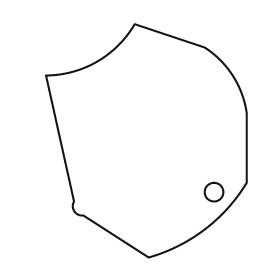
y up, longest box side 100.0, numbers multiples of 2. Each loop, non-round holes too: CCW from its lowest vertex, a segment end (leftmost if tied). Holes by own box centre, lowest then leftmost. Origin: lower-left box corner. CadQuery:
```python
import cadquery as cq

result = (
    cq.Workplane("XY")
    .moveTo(44.0, 0.0)
    .threePointArc((68.0, 12.0), (86.0, 32.0))
    .lineTo(86.0, 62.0)
    .threePointArc((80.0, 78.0), (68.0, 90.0))
    .lineTo(38.0, 100.0)
    .threePointArc((22.0, 84.0), (0.0, 78.0))
    .lineTo(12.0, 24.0)
    .threePointArc((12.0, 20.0), (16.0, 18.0))
    .close()
    .moveTo(72.0, 28.0)
    .circle(4.0)
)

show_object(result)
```